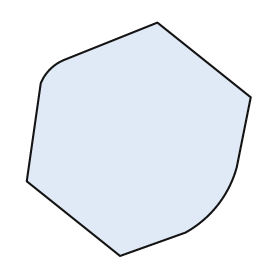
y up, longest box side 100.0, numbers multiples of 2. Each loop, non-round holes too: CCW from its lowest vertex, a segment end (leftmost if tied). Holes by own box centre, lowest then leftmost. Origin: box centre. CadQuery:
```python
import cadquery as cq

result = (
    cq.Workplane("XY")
    .moveTo(-8.0, -50.0)
    .lineTo(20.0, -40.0)
    .threePointArc((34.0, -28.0), (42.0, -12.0))
    .lineTo(48.0, 18.0)
    .lineTo(8.0, 50.0)
    .lineTo(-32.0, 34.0)
    .threePointArc((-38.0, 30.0), (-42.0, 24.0))
    .lineTo(-48.0, -18.0)
    .close()
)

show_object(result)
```